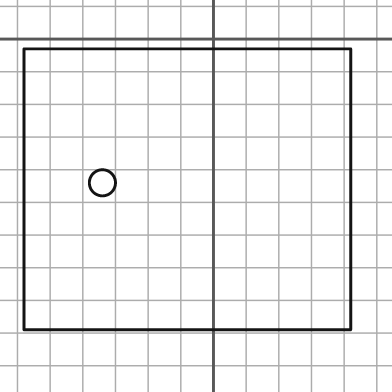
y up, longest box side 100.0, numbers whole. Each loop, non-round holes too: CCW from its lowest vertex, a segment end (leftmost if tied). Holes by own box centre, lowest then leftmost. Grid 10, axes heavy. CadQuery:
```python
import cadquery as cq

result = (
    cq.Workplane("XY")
    .moveTo(-58.0, -89.0)
    .lineTo(42.0, -89.0)
    .lineTo(42.0, -3.0)
    .lineTo(-58.0, -3.0)
    .close()
    .moveTo(-34.0, -44.0)
    .circle(4.0)
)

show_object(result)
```